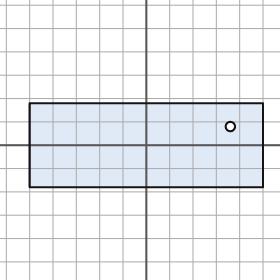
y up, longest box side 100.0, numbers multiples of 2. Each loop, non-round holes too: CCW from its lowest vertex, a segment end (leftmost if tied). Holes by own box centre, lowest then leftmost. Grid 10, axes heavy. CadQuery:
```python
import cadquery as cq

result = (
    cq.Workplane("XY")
    .moveTo(-50.0, -18.0)
    .lineTo(50.0, -18.0)
    .lineTo(50.0, 18.0)
    .lineTo(-50.0, 18.0)
    .close()
    .moveTo(36.0, 8.0)
    .circle(2.0)
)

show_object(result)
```